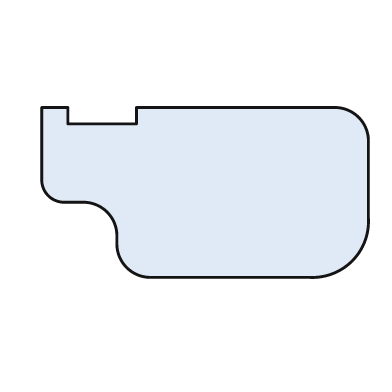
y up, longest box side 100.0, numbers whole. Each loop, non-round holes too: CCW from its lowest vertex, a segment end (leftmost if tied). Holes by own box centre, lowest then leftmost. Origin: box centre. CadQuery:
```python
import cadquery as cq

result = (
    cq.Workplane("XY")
    .moveTo(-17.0, -26.0)
    .lineTo(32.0, -26.0)
    .threePointArc((45.0, -21.0), (50.0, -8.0))
    .lineTo(50.0, 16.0)
    .threePointArc((47.0, 23.0), (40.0, 26.0))
    .lineTo(-21.0, 26.0)
    .lineTo(-21.0, 21.0)
    .lineTo(-42.0, 21.0)
    .lineTo(-42.0, 26.0)
    .lineTo(-50.0, 26.0)
    .lineTo(-50.0, 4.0)
    .threePointArc((-48.0, -1.0), (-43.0, -3.0))
    .lineTo(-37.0, -3.0)
    .threePointArc((-30.0, -6.0), (-27.0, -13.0))
    .lineTo(-27.0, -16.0)
    .threePointArc((-24.0, -23.0), (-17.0, -26.0))
    .close()
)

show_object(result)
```